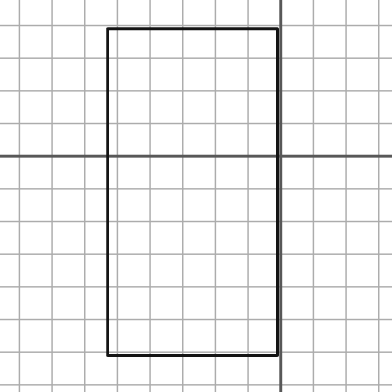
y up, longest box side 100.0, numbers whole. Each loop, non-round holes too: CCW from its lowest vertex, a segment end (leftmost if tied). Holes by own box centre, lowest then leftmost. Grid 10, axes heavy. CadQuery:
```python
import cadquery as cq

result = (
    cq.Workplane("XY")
    .moveTo(-53.0, -61.0)
    .lineTo(-1.0, -61.0)
    .lineTo(-1.0, 39.0)
    .lineTo(-53.0, 39.0)
    .close()
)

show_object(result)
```